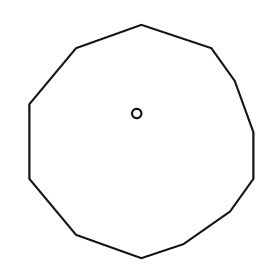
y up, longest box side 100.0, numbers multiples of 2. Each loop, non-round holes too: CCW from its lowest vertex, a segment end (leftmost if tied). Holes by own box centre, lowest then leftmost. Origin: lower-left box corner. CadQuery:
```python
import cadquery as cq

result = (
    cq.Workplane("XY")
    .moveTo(48.0, 0.0)
    .lineTo(66.0, 6.0)
    .lineTo(86.0, 20.0)
    .lineTo(96.0, 34.0)
    .lineTo(96.0, 54.0)
    .lineTo(88.0, 76.0)
    .lineTo(78.0, 90.0)
    .lineTo(48.0, 100.0)
    .lineTo(20.0, 90.0)
    .lineTo(0.0, 66.0)
    .lineTo(0.0, 34.0)
    .lineTo(20.0, 10.0)
    .close()
    .moveTo(46.0, 62.0)
    .circle(2.0)
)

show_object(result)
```